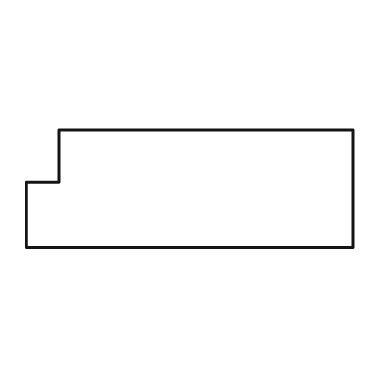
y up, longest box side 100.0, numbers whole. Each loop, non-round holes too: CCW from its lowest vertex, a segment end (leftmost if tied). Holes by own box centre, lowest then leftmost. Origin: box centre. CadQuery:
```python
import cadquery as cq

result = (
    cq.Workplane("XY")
    .moveTo(-50.0, -18.0)
    .lineTo(50.0, -18.0)
    .lineTo(50.0, 18.0)
    .lineTo(-40.0, 18.0)
    .lineTo(-40.0, 2.0)
    .lineTo(-50.0, 2.0)
    .close()
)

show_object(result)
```